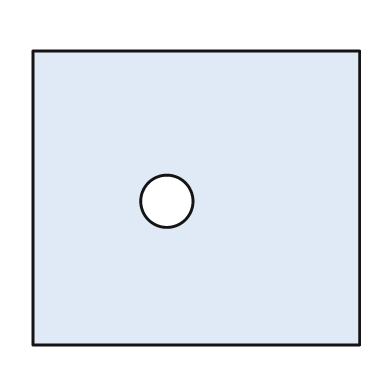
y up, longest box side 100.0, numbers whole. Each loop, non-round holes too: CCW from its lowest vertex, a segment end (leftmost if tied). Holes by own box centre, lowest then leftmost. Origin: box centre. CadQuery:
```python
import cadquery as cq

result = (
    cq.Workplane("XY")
    .moveTo(-50.0, -45.0)
    .lineTo(50.0, -45.0)
    .lineTo(50.0, 45.0)
    .lineTo(-50.0, 45.0)
    .close()
    .moveTo(-9.0, -1.0)
    .circle(8.0)
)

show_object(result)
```